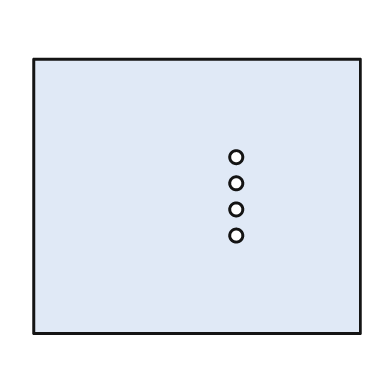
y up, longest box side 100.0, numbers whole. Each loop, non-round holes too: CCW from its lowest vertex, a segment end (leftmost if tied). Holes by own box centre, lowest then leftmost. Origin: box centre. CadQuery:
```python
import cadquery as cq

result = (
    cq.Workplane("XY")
    .moveTo(-50.0, -42.0)
    .lineTo(50.0, -42.0)
    .lineTo(50.0, 42.0)
    .lineTo(-50.0, 42.0)
    .close()
    .moveTo(12.0, -12.0)
    .circle(2.0)
    .moveTo(12.0, -4.0)
    .circle(2.0)
    .moveTo(12.0, 4.0)
    .circle(2.0)
    .moveTo(12.0, 12.0)
    .circle(2.0)
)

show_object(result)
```